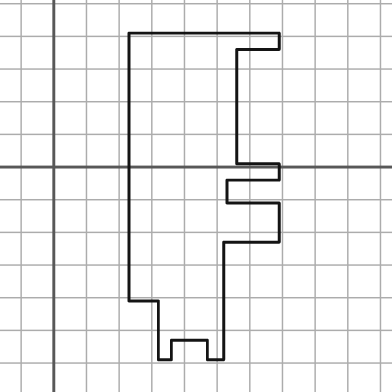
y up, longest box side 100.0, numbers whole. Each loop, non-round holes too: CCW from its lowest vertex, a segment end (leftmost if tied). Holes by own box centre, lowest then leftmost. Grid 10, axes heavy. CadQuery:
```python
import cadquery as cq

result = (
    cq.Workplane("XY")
    .moveTo(32.0, -59.0)
    .lineTo(36.0, -59.0)
    .lineTo(36.0, -53.0)
    .lineTo(47.0, -53.0)
    .lineTo(47.0, -59.0)
    .lineTo(52.0, -59.0)
    .lineTo(52.0, -23.0)
    .lineTo(69.0, -23.0)
    .lineTo(69.0, -11.0)
    .lineTo(53.0, -11.0)
    .lineTo(53.0, -4.0)
    .lineTo(69.0, -4.0)
    .lineTo(69.0, 1.0)
    .lineTo(56.0, 1.0)
    .lineTo(56.0, 36.0)
    .lineTo(69.0, 36.0)
    .lineTo(69.0, 41.0)
    .lineTo(23.0, 41.0)
    .lineTo(23.0, -41.0)
    .lineTo(32.0, -41.0)
    .close()
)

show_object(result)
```